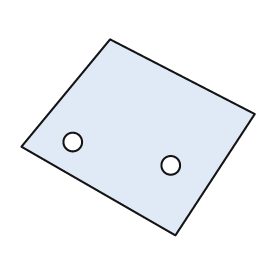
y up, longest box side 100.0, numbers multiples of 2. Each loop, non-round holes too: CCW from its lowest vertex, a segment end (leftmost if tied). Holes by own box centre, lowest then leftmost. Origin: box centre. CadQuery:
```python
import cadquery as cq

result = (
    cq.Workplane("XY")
    .moveTo(16.0, -42.0)
    .lineTo(50.0, 10.0)
    .lineTo(-12.0, 42.0)
    .lineTo(-50.0, -4.0)
    .close()
    .moveTo(14.0, -12.0)
    .circle(4.0)
    .moveTo(-28.0, -2.0)
    .circle(4.0)
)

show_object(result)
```